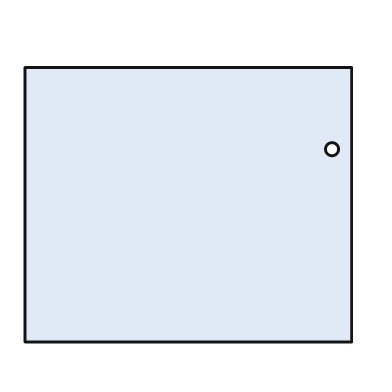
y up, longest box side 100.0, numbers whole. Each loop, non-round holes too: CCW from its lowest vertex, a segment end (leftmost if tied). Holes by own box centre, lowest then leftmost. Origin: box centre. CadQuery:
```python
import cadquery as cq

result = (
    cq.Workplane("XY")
    .moveTo(-50.0, -42.0)
    .lineTo(50.0, -42.0)
    .lineTo(50.0, 42.0)
    .lineTo(-50.0, 42.0)
    .close()
    .moveTo(44.0, 17.0)
    .circle(2.0)
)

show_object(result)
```